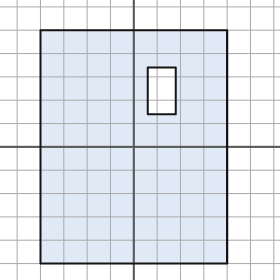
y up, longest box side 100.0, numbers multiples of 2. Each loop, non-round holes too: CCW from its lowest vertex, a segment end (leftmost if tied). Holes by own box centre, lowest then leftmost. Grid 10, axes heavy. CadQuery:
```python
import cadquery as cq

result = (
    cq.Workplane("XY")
    .moveTo(-40.0, -50.0)
    .lineTo(40.0, -50.0)
    .lineTo(40.0, 50.0)
    .lineTo(-40.0, 50.0)
    .close()
    .moveTo(6.0, 14.0)
    .lineTo(18.0, 14.0)
    .lineTo(18.0, 34.0)
    .lineTo(6.0, 34.0)
    .close()
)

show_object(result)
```